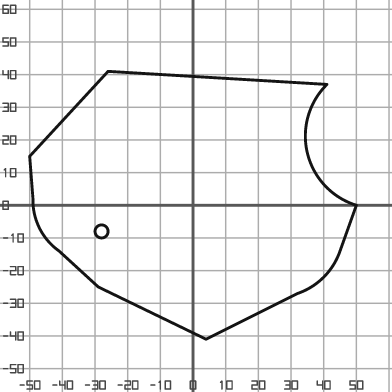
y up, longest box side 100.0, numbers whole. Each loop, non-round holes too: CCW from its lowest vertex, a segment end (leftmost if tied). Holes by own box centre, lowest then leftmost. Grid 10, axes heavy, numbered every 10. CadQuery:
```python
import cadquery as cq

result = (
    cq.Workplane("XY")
    .moveTo(4.0, -41.0)
    .lineTo(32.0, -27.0)
    .threePointArc((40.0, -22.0), (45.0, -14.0))
    .lineTo(50.0, 0.0)
    .threePointArc((35.0, 16.0), (41.0, 37.0))
    .lineTo(-26.0, 41.0)
    .lineTo(-50.0, 15.0)
    .lineTo(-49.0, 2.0)
    .threePointArc((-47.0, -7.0), (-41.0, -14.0))
    .lineTo(-29.0, -25.0)
    .close()
    .moveTo(-28.0, -8.0)
    .circle(2.0)
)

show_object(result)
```